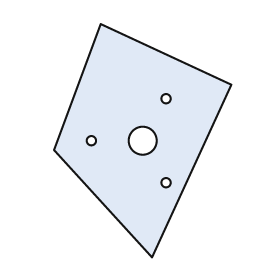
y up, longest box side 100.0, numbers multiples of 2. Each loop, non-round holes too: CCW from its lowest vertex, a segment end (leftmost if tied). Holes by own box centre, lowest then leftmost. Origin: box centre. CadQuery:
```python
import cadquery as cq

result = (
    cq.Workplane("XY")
    .moveTo(4.0, -50.0)
    .lineTo(38.0, 24.0)
    .lineTo(-18.0, 50.0)
    .lineTo(-38.0, -4.0)
    .close()
    .moveTo(10.0, -18.0)
    .circle(2.0)
    .moveTo(-22.0, 0.0)
    .circle(2.0)
    .moveTo(0.0, 0.0)
    .circle(6.0)
    .moveTo(10.0, 18.0)
    .circle(2.0)
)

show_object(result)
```